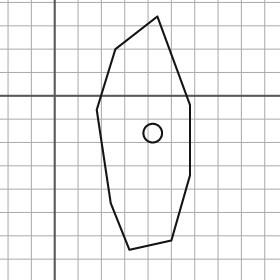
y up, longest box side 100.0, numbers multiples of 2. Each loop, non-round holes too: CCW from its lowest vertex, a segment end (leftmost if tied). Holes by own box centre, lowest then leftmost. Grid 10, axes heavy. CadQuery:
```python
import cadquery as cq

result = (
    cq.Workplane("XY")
    .moveTo(32.0, -66.0)
    .lineTo(50.0, -62.0)
    .lineTo(58.0, -34.0)
    .lineTo(58.0, -4.0)
    .lineTo(44.0, 34.0)
    .lineTo(26.0, 20.0)
    .lineTo(18.0, -6.0)
    .lineTo(24.0, -46.0)
    .close()
    .moveTo(42.0, -16.0)
    .circle(4.0)
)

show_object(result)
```